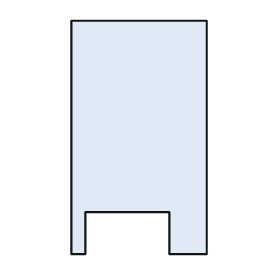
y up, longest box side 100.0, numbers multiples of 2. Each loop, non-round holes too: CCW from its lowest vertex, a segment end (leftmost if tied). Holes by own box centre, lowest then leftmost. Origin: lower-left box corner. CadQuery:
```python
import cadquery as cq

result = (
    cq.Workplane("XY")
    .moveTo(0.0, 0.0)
    .lineTo(6.0, 0.0)
    .lineTo(6.0, 18.0)
    .lineTo(42.0, 18.0)
    .lineTo(42.0, 0.0)
    .lineTo(58.0, 0.0)
    .lineTo(58.0, 100.0)
    .lineTo(0.0, 100.0)
    .close()
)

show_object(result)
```